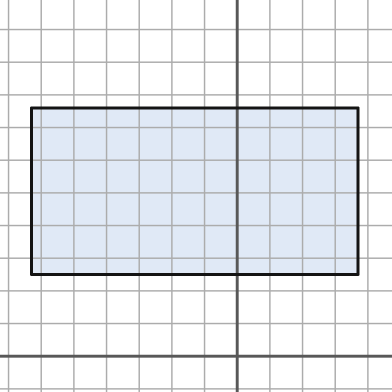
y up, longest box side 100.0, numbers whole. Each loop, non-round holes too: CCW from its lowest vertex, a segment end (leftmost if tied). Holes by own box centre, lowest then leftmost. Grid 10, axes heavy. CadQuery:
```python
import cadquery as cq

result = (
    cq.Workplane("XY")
    .moveTo(-63.0, 25.0)
    .lineTo(37.0, 25.0)
    .lineTo(37.0, 76.0)
    .lineTo(-63.0, 76.0)
    .close()
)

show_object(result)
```